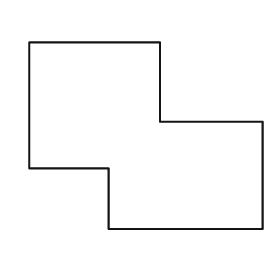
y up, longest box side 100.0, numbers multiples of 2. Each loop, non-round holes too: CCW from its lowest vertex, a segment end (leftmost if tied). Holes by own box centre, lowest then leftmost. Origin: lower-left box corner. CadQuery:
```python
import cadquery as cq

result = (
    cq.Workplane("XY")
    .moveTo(34.0, 0.0)
    .lineTo(100.0, 0.0)
    .lineTo(100.0, 46.0)
    .lineTo(56.0, 46.0)
    .lineTo(56.0, 80.0)
    .lineTo(0.0, 80.0)
    .lineTo(0.0, 26.0)
    .lineTo(34.0, 26.0)
    .close()
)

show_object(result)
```